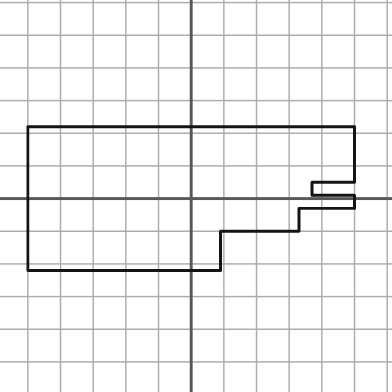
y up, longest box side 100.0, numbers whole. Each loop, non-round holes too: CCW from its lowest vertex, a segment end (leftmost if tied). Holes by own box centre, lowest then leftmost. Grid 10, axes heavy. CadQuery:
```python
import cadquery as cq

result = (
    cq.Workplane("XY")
    .moveTo(-50.0, -22.0)
    .lineTo(9.0, -22.0)
    .lineTo(9.0, -10.0)
    .lineTo(33.0, -10.0)
    .lineTo(33.0, -3.0)
    .lineTo(50.0, -3.0)
    .lineTo(50.0, 1.0)
    .lineTo(37.0, 1.0)
    .lineTo(37.0, 5.0)
    .lineTo(50.0, 5.0)
    .lineTo(50.0, 22.0)
    .lineTo(-50.0, 22.0)
    .close()
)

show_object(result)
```